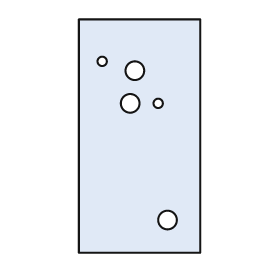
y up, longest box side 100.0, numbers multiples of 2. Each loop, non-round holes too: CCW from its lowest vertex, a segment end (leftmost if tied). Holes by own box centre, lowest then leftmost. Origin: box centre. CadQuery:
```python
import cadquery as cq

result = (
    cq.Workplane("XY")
    .moveTo(-26.0, -50.0)
    .lineTo(26.0, -50.0)
    .lineTo(26.0, 50.0)
    .lineTo(-26.0, 50.0)
    .close()
    .moveTo(12.0, -36.0)
    .circle(4.0)
    .moveTo(-4.0, 14.0)
    .circle(4.0)
    .moveTo(8.0, 14.0)
    .circle(2.0)
    .moveTo(-2.0, 28.0)
    .circle(4.0)
    .moveTo(-16.0, 32.0)
    .circle(2.0)
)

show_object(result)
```